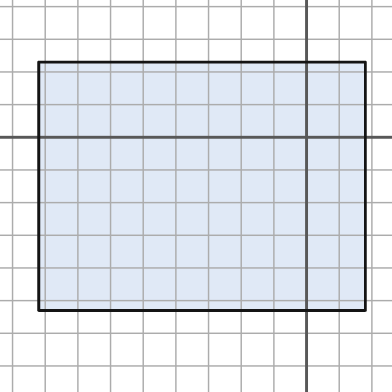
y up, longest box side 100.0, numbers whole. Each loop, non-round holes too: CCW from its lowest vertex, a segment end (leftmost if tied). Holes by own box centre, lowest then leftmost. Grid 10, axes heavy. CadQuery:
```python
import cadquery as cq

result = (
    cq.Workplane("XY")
    .moveTo(-82.0, -53.0)
    .lineTo(18.0, -53.0)
    .lineTo(18.0, 23.0)
    .lineTo(-82.0, 23.0)
    .close()
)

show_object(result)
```